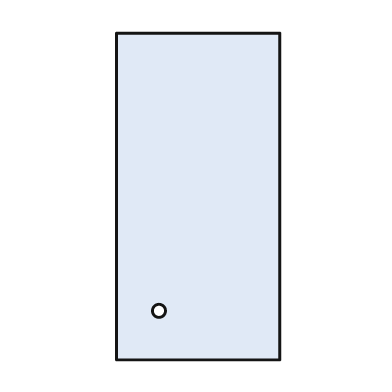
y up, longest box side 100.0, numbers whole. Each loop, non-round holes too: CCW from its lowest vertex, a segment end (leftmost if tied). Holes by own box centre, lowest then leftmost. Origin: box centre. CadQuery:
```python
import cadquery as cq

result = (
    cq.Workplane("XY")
    .moveTo(-25.0, -50.0)
    .lineTo(25.0, -50.0)
    .lineTo(25.0, 50.0)
    .lineTo(-25.0, 50.0)
    .close()
    .moveTo(-12.0, -35.0)
    .circle(2.0)
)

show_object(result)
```